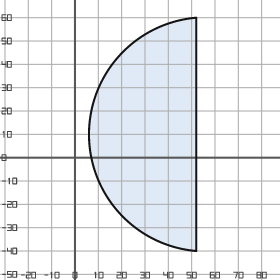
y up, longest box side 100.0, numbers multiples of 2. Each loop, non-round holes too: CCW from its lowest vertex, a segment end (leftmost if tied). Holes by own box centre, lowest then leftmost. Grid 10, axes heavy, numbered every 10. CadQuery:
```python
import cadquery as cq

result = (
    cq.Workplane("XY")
    .moveTo(52.0, -40.0)
    .lineTo(52.0, 60.0)
    .threePointArc((6.0, 10.0), (52.0, -40.0))
    .close()
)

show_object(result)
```